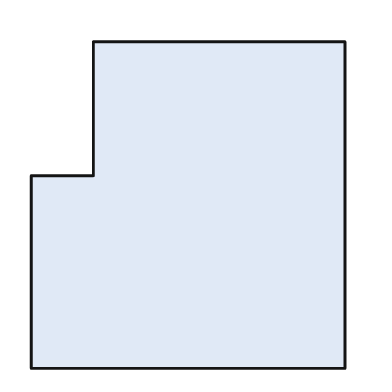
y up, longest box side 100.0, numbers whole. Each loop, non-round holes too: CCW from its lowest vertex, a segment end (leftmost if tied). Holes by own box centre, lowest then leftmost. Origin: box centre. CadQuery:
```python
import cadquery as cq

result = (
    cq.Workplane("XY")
    .moveTo(-48.0, -50.0)
    .lineTo(48.0, -50.0)
    .lineTo(48.0, 50.0)
    .lineTo(-29.0, 50.0)
    .lineTo(-29.0, 9.0)
    .lineTo(-48.0, 9.0)
    .close()
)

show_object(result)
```